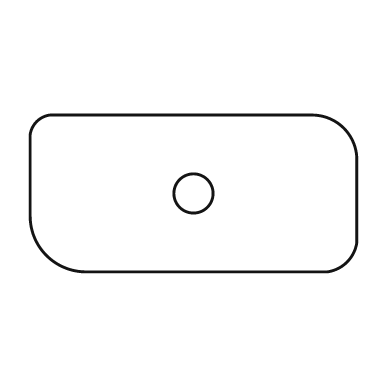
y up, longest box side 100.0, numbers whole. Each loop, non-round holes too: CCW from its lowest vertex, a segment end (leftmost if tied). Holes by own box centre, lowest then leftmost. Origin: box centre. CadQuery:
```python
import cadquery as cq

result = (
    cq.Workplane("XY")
    .moveTo(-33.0, -24.0)
    .lineTo(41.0, -24.0)
    .threePointArc((47.0, -21.0), (50.0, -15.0))
    .lineTo(50.0, 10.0)
    .threePointArc((46.0, 20.0), (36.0, 24.0))
    .lineTo(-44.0, 24.0)
    .threePointArc((-48.0, 22.0), (-50.0, 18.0))
    .lineTo(-50.0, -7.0)
    .threePointArc((-45.0, -19.0), (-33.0, -24.0))
    .close()
    .moveTo(0.0, 0.0)
    .circle(6.0)
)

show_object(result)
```